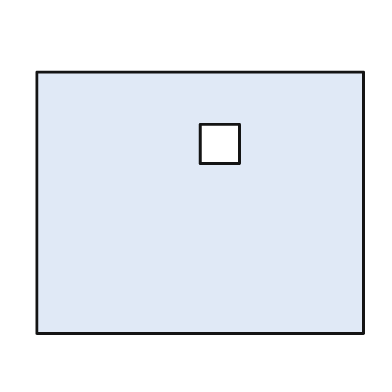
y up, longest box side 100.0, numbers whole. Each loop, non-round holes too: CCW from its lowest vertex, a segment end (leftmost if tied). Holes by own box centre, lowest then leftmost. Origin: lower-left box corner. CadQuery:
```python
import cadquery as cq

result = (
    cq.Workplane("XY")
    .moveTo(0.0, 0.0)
    .lineTo(100.0, 0.0)
    .lineTo(100.0, 80.0)
    .lineTo(0.0, 80.0)
    .close()
    .moveTo(50.0, 52.0)
    .lineTo(62.0, 52.0)
    .lineTo(62.0, 64.0)
    .lineTo(50.0, 64.0)
    .close()
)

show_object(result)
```